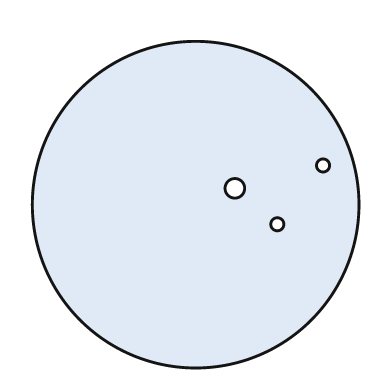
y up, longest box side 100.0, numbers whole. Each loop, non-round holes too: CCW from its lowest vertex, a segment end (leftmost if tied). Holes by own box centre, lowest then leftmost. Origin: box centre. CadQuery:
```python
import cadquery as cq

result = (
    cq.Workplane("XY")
    .moveTo(0.0, 0.0)
    .circle(50.0)
    .moveTo(25.0, -6.0)
    .circle(2.0)
    .moveTo(12.0, 5.0)
    .circle(3.0)
    .moveTo(39.0, 12.0)
    .circle(2.0)
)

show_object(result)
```